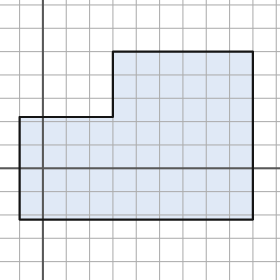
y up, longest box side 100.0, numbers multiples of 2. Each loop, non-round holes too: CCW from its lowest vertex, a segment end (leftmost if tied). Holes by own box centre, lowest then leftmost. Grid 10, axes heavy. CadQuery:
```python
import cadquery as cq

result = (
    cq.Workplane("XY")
    .moveTo(-10.0, -22.0)
    .lineTo(90.0, -22.0)
    .lineTo(90.0, 50.0)
    .lineTo(30.0, 50.0)
    .lineTo(30.0, 22.0)
    .lineTo(-10.0, 22.0)
    .close()
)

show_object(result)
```